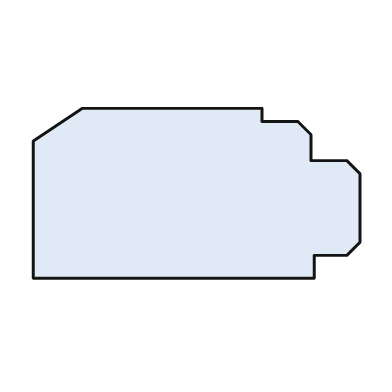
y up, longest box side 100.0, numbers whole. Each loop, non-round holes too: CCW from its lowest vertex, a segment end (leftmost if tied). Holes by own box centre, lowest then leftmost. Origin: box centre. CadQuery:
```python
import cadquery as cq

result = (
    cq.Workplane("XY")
    .moveTo(-50.0, -26.0)
    .lineTo(36.0, -26.0)
    .lineTo(36.0, -19.0)
    .lineTo(46.0, -19.0)
    .lineTo(50.0, -15.0)
    .lineTo(50.0, 6.0)
    .lineTo(46.0, 10.0)
    .lineTo(35.0, 10.0)
    .lineTo(35.0, 18.0)
    .lineTo(31.0, 22.0)
    .lineTo(20.0, 22.0)
    .lineTo(20.0, 26.0)
    .lineTo(-35.0, 26.0)
    .lineTo(-50.0, 16.0)
    .close()
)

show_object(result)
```